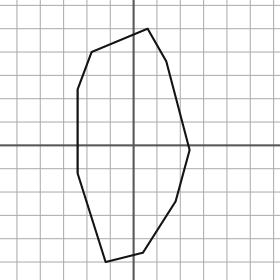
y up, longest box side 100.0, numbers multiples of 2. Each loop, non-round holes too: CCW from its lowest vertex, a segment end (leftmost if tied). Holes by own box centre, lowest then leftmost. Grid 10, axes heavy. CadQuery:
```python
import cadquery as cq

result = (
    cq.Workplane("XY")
    .moveTo(-12.0, -50.0)
    .lineTo(4.0, -46.0)
    .lineTo(18.0, -24.0)
    .lineTo(24.0, -2.0)
    .lineTo(14.0, 36.0)
    .lineTo(6.0, 50.0)
    .lineTo(-18.0, 40.0)
    .lineTo(-24.0, 24.0)
    .lineTo(-24.0, -12.0)
    .close()
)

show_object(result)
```